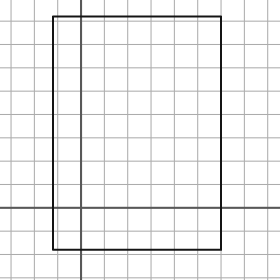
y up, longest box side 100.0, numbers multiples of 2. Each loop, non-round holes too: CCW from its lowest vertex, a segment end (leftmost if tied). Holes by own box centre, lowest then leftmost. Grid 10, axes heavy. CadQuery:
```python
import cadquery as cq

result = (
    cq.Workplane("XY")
    .moveTo(-12.0, -18.0)
    .lineTo(60.0, -18.0)
    .lineTo(60.0, 82.0)
    .lineTo(-12.0, 82.0)
    .close()
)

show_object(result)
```